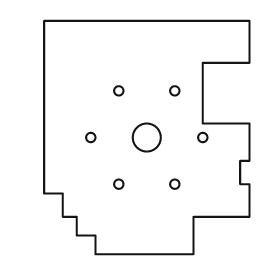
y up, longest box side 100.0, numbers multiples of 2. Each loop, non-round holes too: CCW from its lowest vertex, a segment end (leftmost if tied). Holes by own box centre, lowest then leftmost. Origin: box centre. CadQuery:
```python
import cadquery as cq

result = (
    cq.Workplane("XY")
    .moveTo(-22.0, -50.0)
    .lineTo(20.0, -50.0)
    .lineTo(20.0, -34.0)
    .lineTo(44.0, -34.0)
    .lineTo(44.0, -20.0)
    .lineTo(40.0, -20.0)
    .lineTo(40.0, -10.0)
    .lineTo(44.0, -10.0)
    .lineTo(44.0, 6.0)
    .lineTo(24.0, 6.0)
    .lineTo(24.0, 32.0)
    .lineTo(44.0, 32.0)
    .lineTo(44.0, 50.0)
    .lineTo(-44.0, 50.0)
    .lineTo(-44.0, -24.0)
    .lineTo(-36.0, -24.0)
    .lineTo(-36.0, -34.0)
    .lineTo(-30.0, -34.0)
    .lineTo(-30.0, -42.0)
    .lineTo(-22.0, -42.0)
    .close()
    .moveTo(-12.0, -20.0)
    .circle(2.0)
    .moveTo(12.0, -20.0)
    .circle(2.0)
    .moveTo(-24.0, 0.0)
    .circle(2.0)
    .moveTo(0.0, 0.0)
    .circle(6.0)
    .moveTo(24.0, 0.0)
    .circle(2.0)
    .moveTo(-12.0, 20.0)
    .circle(2.0)
    .moveTo(12.0, 20.0)
    .circle(2.0)
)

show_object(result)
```